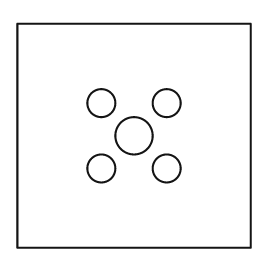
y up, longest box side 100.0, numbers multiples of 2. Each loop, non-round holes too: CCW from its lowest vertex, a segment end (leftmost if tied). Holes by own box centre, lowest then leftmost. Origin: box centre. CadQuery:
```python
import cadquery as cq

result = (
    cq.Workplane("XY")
    .moveTo(-50.0, -48.0)
    .lineTo(50.0, -48.0)
    .lineTo(50.0, 48.0)
    .lineTo(-50.0, 48.0)
    .close()
    .moveTo(-14.0, -14.0)
    .circle(6.0)
    .moveTo(14.0, -14.0)
    .circle(6.0)
    .moveTo(0.0, 0.0)
    .circle(8.0)
    .moveTo(-14.0, 14.0)
    .circle(6.0)
    .moveTo(14.0, 14.0)
    .circle(6.0)
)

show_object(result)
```